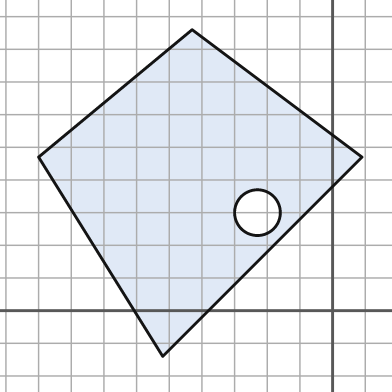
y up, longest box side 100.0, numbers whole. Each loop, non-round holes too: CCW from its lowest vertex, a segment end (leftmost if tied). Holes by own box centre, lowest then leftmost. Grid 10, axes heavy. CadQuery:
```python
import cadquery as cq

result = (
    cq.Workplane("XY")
    .moveTo(-52.0, -14.0)
    .lineTo(9.0, 47.0)
    .lineTo(-43.0, 86.0)
    .lineTo(-90.0, 47.0)
    .close()
    .moveTo(-23.0, 30.0)
    .circle(7.0)
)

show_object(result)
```